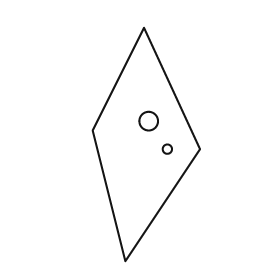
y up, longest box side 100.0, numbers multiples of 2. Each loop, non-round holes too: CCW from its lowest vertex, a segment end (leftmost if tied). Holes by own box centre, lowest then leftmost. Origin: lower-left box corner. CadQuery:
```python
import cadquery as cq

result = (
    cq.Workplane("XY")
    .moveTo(14.0, 0.0)
    .lineTo(46.0, 48.0)
    .lineTo(22.0, 100.0)
    .lineTo(0.0, 56.0)
    .close()
    .moveTo(32.0, 48.0)
    .circle(2.0)
    .moveTo(24.0, 60.0)
    .circle(4.0)
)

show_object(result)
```